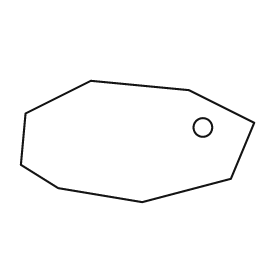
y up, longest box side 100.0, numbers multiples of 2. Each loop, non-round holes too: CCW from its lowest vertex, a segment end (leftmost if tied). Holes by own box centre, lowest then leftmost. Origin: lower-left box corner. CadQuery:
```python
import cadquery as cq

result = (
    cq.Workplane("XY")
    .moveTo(52.0, 0.0)
    .lineTo(90.0, 10.0)
    .lineTo(100.0, 34.0)
    .lineTo(72.0, 48.0)
    .lineTo(30.0, 52.0)
    .lineTo(2.0, 38.0)
    .lineTo(0.0, 16.0)
    .lineTo(16.0, 6.0)
    .close()
    .moveTo(78.0, 32.0)
    .circle(4.0)
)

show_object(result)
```